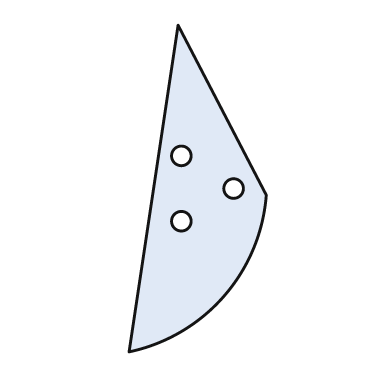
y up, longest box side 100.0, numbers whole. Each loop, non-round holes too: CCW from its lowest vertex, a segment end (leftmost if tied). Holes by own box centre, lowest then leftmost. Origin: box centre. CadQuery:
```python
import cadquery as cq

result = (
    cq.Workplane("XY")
    .moveTo(-21.0, -50.0)
    .threePointArc((8.0, -33.0), (21.0, -2.0))
    .lineTo(-6.0, 50.0)
    .close()
    .moveTo(-5.0, -10.0)
    .circle(3.0)
    .moveTo(11.0, 0.0)
    .circle(3.0)
    .moveTo(-5.0, 10.0)
    .circle(3.0)
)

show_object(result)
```